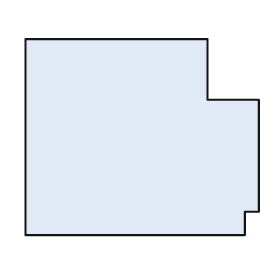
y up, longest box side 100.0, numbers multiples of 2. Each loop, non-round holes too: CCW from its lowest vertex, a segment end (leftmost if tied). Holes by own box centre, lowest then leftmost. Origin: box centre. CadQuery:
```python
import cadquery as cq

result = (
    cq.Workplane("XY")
    .moveTo(-50.0, -42.0)
    .lineTo(44.0, -42.0)
    .lineTo(44.0, -32.0)
    .lineTo(50.0, -32.0)
    .lineTo(50.0, 16.0)
    .lineTo(28.0, 16.0)
    .lineTo(28.0, 42.0)
    .lineTo(-50.0, 42.0)
    .close()
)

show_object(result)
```